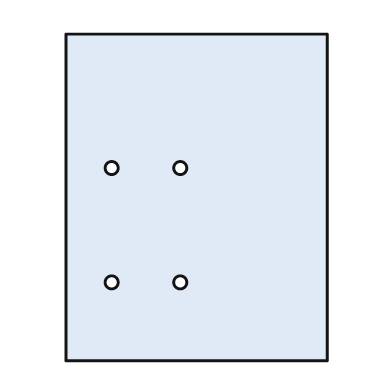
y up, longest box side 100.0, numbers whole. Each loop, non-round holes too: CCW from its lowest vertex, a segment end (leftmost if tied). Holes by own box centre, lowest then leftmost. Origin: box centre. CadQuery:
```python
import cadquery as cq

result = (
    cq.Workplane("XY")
    .moveTo(-40.0, -50.0)
    .lineTo(40.0, -50.0)
    .lineTo(40.0, 50.0)
    .lineTo(-40.0, 50.0)
    .close()
    .moveTo(-26.0, -26.0)
    .circle(2.0)
    .moveTo(-5.0, -26.0)
    .circle(2.0)
    .moveTo(-26.0, 9.0)
    .circle(2.0)
    .moveTo(-5.0, 9.0)
    .circle(2.0)
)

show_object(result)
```